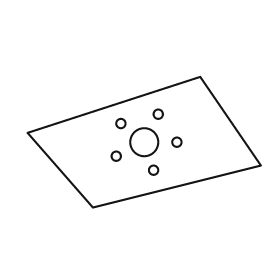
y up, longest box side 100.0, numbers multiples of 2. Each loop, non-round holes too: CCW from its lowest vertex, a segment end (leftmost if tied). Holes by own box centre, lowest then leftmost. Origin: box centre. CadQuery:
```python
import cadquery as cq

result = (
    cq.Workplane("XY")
    .moveTo(-22.0, -28.0)
    .lineTo(50.0, -10.0)
    .lineTo(24.0, 28.0)
    .lineTo(-50.0, 4.0)
    .close()
    .moveTo(4.0, -12.0)
    .circle(2.0)
    .moveTo(-12.0, -6.0)
    .circle(2.0)
    .moveTo(0.0, 0.0)
    .circle(6.0)
    .moveTo(14.0, 0.0)
    .circle(2.0)
    .moveTo(-10.0, 8.0)
    .circle(2.0)
    .moveTo(6.0, 12.0)
    .circle(2.0)
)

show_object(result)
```